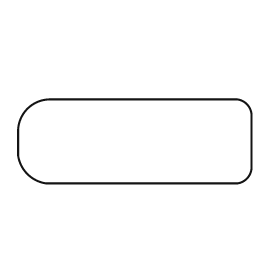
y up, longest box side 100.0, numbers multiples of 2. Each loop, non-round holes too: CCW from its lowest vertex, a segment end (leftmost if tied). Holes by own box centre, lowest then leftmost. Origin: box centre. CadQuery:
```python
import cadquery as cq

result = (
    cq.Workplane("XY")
    .moveTo(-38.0, -18.0)
    .lineTo(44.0, -18.0)
    .threePointArc((48.0, -16.0), (50.0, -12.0))
    .lineTo(50.0, 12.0)
    .threePointArc((48.0, 16.0), (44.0, 18.0))
    .lineTo(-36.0, 18.0)
    .threePointArc((-46.0, 14.0), (-50.0, 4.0))
    .lineTo(-50.0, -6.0)
    .threePointArc((-46.0, -14.0), (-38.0, -18.0))
    .close()
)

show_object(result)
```